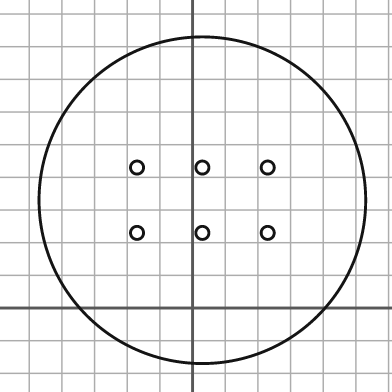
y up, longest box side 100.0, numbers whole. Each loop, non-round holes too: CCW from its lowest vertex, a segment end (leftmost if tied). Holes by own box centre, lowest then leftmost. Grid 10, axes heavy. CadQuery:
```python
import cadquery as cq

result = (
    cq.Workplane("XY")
    .moveTo(3.0, 33.0)
    .circle(50.0)
    .moveTo(-17.0, 23.0)
    .circle(2.0)
    .moveTo(3.0, 23.0)
    .circle(2.0)
    .moveTo(23.0, 23.0)
    .circle(2.0)
    .moveTo(-17.0, 43.0)
    .circle(2.0)
    .moveTo(3.0, 43.0)
    .circle(2.0)
    .moveTo(23.0, 43.0)
    .circle(2.0)
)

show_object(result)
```